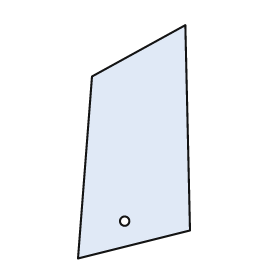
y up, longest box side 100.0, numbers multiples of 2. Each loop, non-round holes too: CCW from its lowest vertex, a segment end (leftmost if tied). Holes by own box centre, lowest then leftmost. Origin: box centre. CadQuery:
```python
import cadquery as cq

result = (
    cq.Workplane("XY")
    .moveTo(-24.0, -50.0)
    .lineTo(24.0, -38.0)
    .lineTo(22.0, 50.0)
    .lineTo(-18.0, 28.0)
    .close()
    .moveTo(-4.0, -34.0)
    .circle(2.0)
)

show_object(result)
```